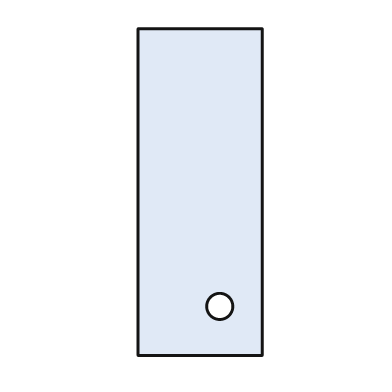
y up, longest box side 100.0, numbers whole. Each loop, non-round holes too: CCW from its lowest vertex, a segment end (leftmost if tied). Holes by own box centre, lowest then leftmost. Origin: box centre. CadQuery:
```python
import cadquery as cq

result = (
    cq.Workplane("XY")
    .moveTo(-19.0, -50.0)
    .lineTo(19.0, -50.0)
    .lineTo(19.0, 50.0)
    .lineTo(-19.0, 50.0)
    .close()
    .moveTo(6.0, -35.0)
    .circle(4.0)
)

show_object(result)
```